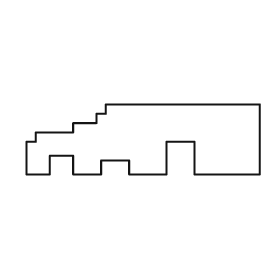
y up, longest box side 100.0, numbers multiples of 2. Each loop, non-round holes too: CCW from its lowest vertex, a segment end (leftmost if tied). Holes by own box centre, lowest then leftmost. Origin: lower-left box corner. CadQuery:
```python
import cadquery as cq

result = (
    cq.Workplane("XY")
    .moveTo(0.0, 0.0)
    .lineTo(10.0, 0.0)
    .lineTo(10.0, 8.0)
    .lineTo(20.0, 8.0)
    .lineTo(20.0, 0.0)
    .lineTo(32.0, 0.0)
    .lineTo(32.0, 6.0)
    .lineTo(44.0, 6.0)
    .lineTo(44.0, 0.0)
    .lineTo(60.0, 0.0)
    .lineTo(60.0, 14.0)
    .lineTo(72.0, 14.0)
    .lineTo(72.0, 0.0)
    .lineTo(100.0, 0.0)
    .lineTo(100.0, 30.0)
    .lineTo(34.0, 30.0)
    .lineTo(34.0, 26.0)
    .lineTo(30.0, 26.0)
    .lineTo(30.0, 22.0)
    .lineTo(20.0, 22.0)
    .lineTo(20.0, 18.0)
    .lineTo(4.0, 18.0)
    .lineTo(4.0, 14.0)
    .lineTo(0.0, 14.0)
    .close()
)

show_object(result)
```